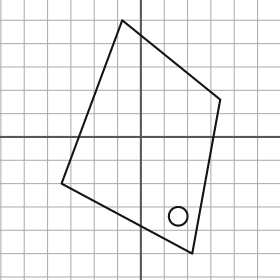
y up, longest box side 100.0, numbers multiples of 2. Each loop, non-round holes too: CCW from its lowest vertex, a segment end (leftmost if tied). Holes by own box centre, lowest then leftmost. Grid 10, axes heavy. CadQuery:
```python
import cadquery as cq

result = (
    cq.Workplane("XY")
    .moveTo(22.0, -50.0)
    .lineTo(34.0, 16.0)
    .lineTo(-8.0, 50.0)
    .lineTo(-34.0, -20.0)
    .close()
    .moveTo(16.0, -34.0)
    .circle(4.0)
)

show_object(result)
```